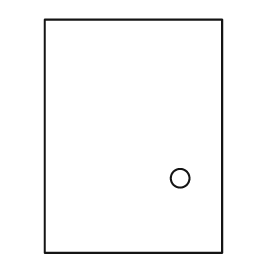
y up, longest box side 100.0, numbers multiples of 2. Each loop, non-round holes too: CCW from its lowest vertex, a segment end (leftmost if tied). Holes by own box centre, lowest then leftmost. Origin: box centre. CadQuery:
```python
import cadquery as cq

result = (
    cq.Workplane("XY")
    .moveTo(-38.0, -50.0)
    .lineTo(38.0, -50.0)
    .lineTo(38.0, 50.0)
    .lineTo(-38.0, 50.0)
    .close()
    .moveTo(20.0, -18.0)
    .circle(4.0)
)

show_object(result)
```